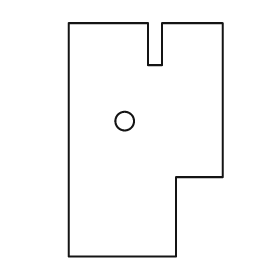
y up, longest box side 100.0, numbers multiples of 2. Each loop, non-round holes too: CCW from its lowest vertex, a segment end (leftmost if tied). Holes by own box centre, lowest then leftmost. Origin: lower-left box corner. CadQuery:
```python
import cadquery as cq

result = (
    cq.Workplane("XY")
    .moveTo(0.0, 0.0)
    .lineTo(46.0, 0.0)
    .lineTo(46.0, 34.0)
    .lineTo(66.0, 34.0)
    .lineTo(66.0, 100.0)
    .lineTo(40.0, 100.0)
    .lineTo(40.0, 82.0)
    .lineTo(34.0, 82.0)
    .lineTo(34.0, 100.0)
    .lineTo(0.0, 100.0)
    .close()
    .moveTo(24.0, 58.0)
    .circle(4.0)
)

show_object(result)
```